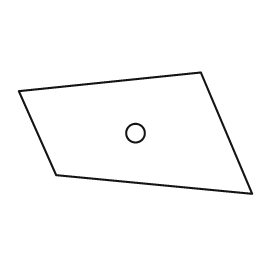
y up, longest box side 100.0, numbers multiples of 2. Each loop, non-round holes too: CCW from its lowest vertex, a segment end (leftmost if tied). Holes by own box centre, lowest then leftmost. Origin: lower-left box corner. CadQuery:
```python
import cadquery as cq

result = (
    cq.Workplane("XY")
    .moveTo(100.0, 0.0)
    .lineTo(78.0, 52.0)
    .lineTo(0.0, 44.0)
    .lineTo(16.0, 8.0)
    .close()
    .moveTo(50.0, 26.0)
    .circle(4.0)
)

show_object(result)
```